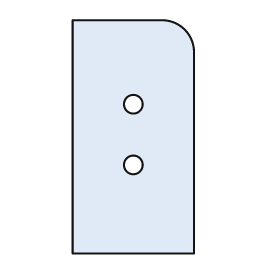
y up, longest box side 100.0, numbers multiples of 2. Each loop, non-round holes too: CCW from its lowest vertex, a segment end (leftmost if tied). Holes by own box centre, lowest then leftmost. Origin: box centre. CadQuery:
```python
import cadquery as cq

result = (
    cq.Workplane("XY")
    .moveTo(-26.0, -50.0)
    .lineTo(26.0, -50.0)
    .lineTo(26.0, 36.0)
    .threePointArc((22.0, 46.0), (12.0, 50.0))
    .lineTo(-26.0, 50.0)
    .close()
    .moveTo(0.0, -12.0)
    .circle(4.0)
    .moveTo(0.0, 14.0)
    .circle(4.0)
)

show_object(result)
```